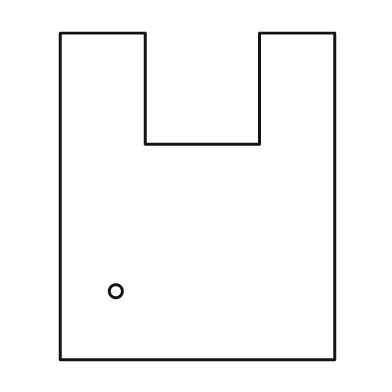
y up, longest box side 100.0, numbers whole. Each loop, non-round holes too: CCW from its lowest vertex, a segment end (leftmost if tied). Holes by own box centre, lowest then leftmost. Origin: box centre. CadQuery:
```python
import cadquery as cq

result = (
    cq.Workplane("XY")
    .moveTo(-42.0, -50.0)
    .lineTo(42.0, -50.0)
    .lineTo(42.0, 50.0)
    .lineTo(19.0, 50.0)
    .lineTo(19.0, 16.0)
    .lineTo(-16.0, 16.0)
    .lineTo(-16.0, 50.0)
    .lineTo(-42.0, 50.0)
    .close()
    .moveTo(-25.0, -29.0)
    .circle(2.0)
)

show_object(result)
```